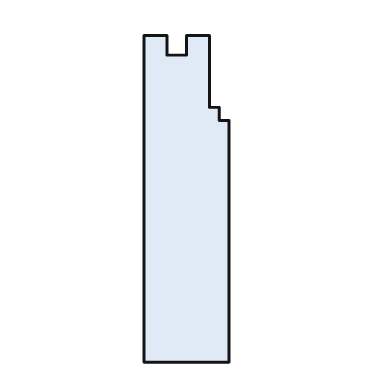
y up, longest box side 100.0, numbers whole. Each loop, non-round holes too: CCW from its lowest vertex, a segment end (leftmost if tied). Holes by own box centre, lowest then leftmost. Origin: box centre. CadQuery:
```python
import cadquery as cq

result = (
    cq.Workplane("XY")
    .moveTo(-13.0, -50.0)
    .lineTo(13.0, -50.0)
    .lineTo(13.0, 24.0)
    .lineTo(10.0, 24.0)
    .lineTo(10.0, 28.0)
    .lineTo(7.0, 28.0)
    .lineTo(7.0, 50.0)
    .lineTo(0.0, 50.0)
    .lineTo(0.0, 44.0)
    .lineTo(-6.0, 44.0)
    .lineTo(-6.0, 50.0)
    .lineTo(-13.0, 50.0)
    .close()
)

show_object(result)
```